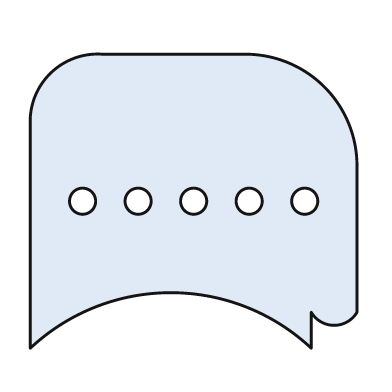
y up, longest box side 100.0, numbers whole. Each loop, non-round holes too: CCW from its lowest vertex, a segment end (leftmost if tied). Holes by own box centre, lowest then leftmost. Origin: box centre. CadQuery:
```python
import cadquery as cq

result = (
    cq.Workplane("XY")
    .moveTo(-50.0, -45.0)
    .threePointArc((-7.0, -28.0), (36.0, -45.0))
    .lineTo(36.0, -34.0)
    .threePointArc((43.0, -38.0), (50.0, -34.0))
    .lineTo(50.0, 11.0)
    .threePointArc((40.0, 35.0), (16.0, 45.0))
    .lineTo(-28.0, 45.0)
    .threePointArc((-44.0, 39.0), (-50.0, 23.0))
    .close()
    .moveTo(-34.0, 0.0)
    .circle(4.0)
    .moveTo(-17.0, 0.0)
    .circle(4.0)
    .moveTo(0.0, 0.0)
    .circle(4.0)
    .moveTo(17.0, 0.0)
    .circle(4.0)
    .moveTo(34.0, 0.0)
    .circle(4.0)
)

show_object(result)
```